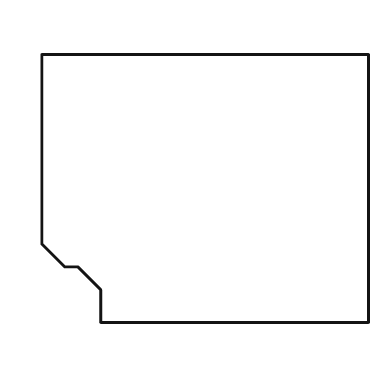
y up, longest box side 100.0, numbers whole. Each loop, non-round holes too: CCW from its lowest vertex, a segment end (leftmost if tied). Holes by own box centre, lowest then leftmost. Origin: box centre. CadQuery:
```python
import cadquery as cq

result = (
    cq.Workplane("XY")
    .moveTo(-32.0, -41.0)
    .lineTo(50.0, -41.0)
    .lineTo(50.0, 41.0)
    .lineTo(-50.0, 41.0)
    .lineTo(-50.0, -17.0)
    .lineTo(-43.0, -24.0)
    .lineTo(-39.0, -24.0)
    .lineTo(-32.0, -31.0)
    .close()
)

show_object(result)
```